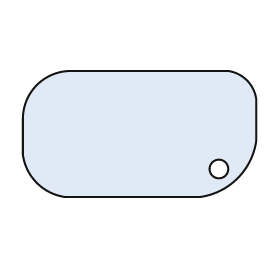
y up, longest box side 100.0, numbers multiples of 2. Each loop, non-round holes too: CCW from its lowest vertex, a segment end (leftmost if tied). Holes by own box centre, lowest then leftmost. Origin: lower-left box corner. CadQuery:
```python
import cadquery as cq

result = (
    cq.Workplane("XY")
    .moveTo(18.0, 0.0)
    .lineTo(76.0, 0.0)
    .threePointArc((92.0, 8.0), (100.0, 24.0))
    .lineTo(100.0, 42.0)
    .threePointArc((96.0, 50.0), (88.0, 54.0))
    .lineTo(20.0, 54.0)
    .threePointArc((6.0, 48.0), (0.0, 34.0))
    .lineTo(0.0, 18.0)
    .threePointArc((6.0, 6.0), (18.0, 0.0))
    .close()
    .moveTo(84.0, 12.0)
    .circle(4.0)
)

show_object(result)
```